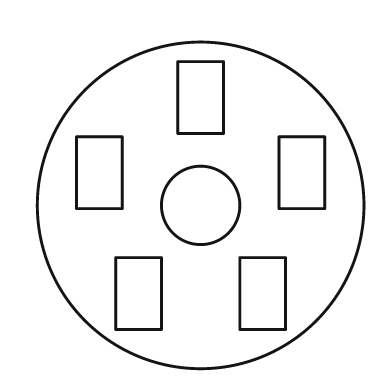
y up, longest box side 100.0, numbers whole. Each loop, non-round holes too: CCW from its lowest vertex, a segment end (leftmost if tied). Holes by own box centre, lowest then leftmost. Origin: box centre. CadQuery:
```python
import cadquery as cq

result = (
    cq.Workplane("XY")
    .moveTo(0.0, 0.0)
    .circle(50.0)
    .moveTo(-26.0, -38.0)
    .lineTo(-12.0, -38.0)
    .lineTo(-12.0, -16.0)
    .lineTo(-26.0, -16.0)
    .close()
    .moveTo(12.0, -38.0)
    .lineTo(26.0, -38.0)
    .lineTo(26.0, -16.0)
    .lineTo(12.0, -16.0)
    .close()
    .moveTo(0.0, 0.0)
    .circle(12.0)
    .moveTo(-38.0, -1.0)
    .lineTo(-24.0, -1.0)
    .lineTo(-24.0, 21.0)
    .lineTo(-38.0, 21.0)
    .close()
    .moveTo(24.0, -1.0)
    .lineTo(38.0, -1.0)
    .lineTo(38.0, 21.0)
    .lineTo(24.0, 21.0)
    .close()
    .moveTo(-7.0, 22.0)
    .lineTo(7.0, 22.0)
    .lineTo(7.0, 44.0)
    .lineTo(-7.0, 44.0)
    .close()
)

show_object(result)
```